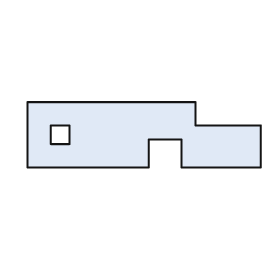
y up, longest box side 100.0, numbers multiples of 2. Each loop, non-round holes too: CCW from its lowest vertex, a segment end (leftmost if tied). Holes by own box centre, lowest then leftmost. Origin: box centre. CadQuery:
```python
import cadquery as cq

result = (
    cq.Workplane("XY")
    .moveTo(-50.0, -14.0)
    .lineTo(2.0, -14.0)
    .lineTo(2.0, -2.0)
    .lineTo(16.0, -2.0)
    .lineTo(16.0, -14.0)
    .lineTo(50.0, -14.0)
    .lineTo(50.0, 4.0)
    .lineTo(22.0, 4.0)
    .lineTo(22.0, 14.0)
    .lineTo(-50.0, 14.0)
    .close()
    .moveTo(-40.0, -4.0)
    .lineTo(-32.0, -4.0)
    .lineTo(-32.0, 4.0)
    .lineTo(-40.0, 4.0)
    .close()
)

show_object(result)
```